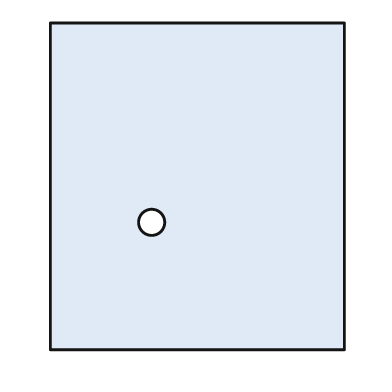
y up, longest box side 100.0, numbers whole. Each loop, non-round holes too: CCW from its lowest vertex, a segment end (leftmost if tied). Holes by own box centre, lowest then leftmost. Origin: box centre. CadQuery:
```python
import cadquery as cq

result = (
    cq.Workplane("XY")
    .moveTo(-45.0, -50.0)
    .lineTo(45.0, -50.0)
    .lineTo(45.0, 50.0)
    .lineTo(-45.0, 50.0)
    .close()
    .moveTo(-14.0, -11.0)
    .circle(4.0)
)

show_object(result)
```